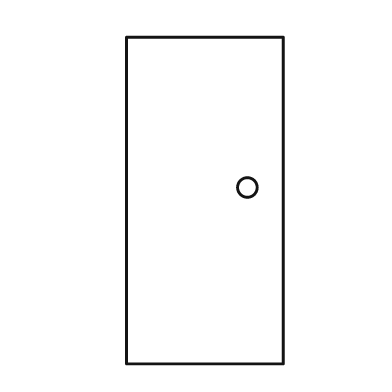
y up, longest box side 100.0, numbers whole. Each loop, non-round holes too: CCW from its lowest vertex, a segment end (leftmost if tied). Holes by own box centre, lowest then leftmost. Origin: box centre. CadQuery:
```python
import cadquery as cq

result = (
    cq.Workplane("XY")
    .moveTo(-24.0, -50.0)
    .lineTo(24.0, -50.0)
    .lineTo(24.0, 50.0)
    .lineTo(-24.0, 50.0)
    .close()
    .moveTo(13.0, 4.0)
    .circle(3.0)
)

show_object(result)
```